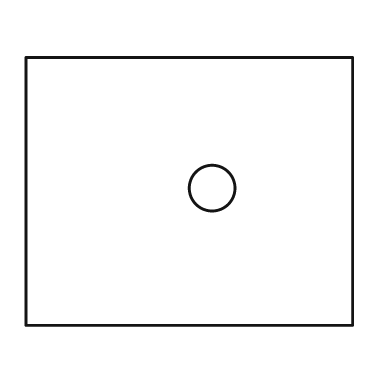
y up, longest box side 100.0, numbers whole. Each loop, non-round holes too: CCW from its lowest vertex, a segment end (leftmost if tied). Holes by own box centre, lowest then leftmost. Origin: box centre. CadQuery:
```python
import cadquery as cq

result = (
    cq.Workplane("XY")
    .moveTo(-50.0, -41.0)
    .lineTo(50.0, -41.0)
    .lineTo(50.0, 41.0)
    .lineTo(-50.0, 41.0)
    .close()
    .moveTo(7.0, 1.0)
    .circle(7.0)
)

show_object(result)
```